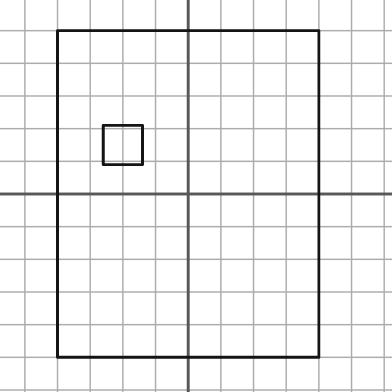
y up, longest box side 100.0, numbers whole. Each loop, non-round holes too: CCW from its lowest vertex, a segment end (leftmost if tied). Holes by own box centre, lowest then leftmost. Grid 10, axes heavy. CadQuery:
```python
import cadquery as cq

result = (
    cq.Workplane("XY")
    .moveTo(-40.0, -50.0)
    .lineTo(40.0, -50.0)
    .lineTo(40.0, 50.0)
    .lineTo(-40.0, 50.0)
    .close()
    .moveTo(-26.0, 9.0)
    .lineTo(-14.0, 9.0)
    .lineTo(-14.0, 21.0)
    .lineTo(-26.0, 21.0)
    .close()
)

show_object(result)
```